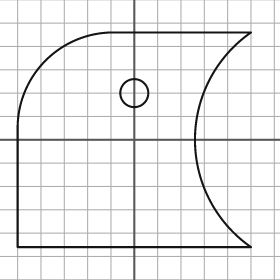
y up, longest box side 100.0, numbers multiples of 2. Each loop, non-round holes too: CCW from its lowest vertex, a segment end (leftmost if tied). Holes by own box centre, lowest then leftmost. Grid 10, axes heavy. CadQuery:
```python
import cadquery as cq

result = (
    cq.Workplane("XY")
    .moveTo(-50.0, -46.0)
    .lineTo(50.0, -46.0)
    .threePointArc((26.0, 0.0), (50.0, 46.0))
    .lineTo(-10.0, 46.0)
    .threePointArc((-38.0, 34.0), (-50.0, 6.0))
    .close()
    .moveTo(0.0, 20.0)
    .circle(6.0)
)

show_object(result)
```